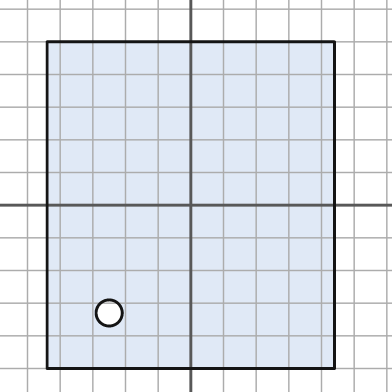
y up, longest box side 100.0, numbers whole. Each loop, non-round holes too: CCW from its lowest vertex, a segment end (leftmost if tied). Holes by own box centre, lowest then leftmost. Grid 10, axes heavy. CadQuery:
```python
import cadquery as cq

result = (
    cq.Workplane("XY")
    .moveTo(-44.0, -50.0)
    .lineTo(44.0, -50.0)
    .lineTo(44.0, 50.0)
    .lineTo(-44.0, 50.0)
    .close()
    .moveTo(-25.0, -33.0)
    .circle(4.0)
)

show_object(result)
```